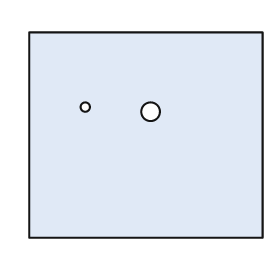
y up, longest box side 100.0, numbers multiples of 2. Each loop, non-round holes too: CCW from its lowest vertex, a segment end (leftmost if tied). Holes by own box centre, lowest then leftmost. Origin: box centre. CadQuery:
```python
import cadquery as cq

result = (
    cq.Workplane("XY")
    .moveTo(-50.0, -44.0)
    .lineTo(50.0, -44.0)
    .lineTo(50.0, 44.0)
    .lineTo(-50.0, 44.0)
    .close()
    .moveTo(2.0, 10.0)
    .circle(4.0)
    .moveTo(-26.0, 12.0)
    .circle(2.0)
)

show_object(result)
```